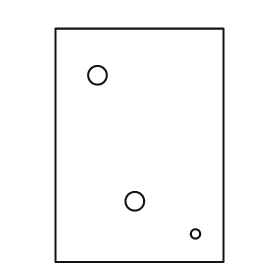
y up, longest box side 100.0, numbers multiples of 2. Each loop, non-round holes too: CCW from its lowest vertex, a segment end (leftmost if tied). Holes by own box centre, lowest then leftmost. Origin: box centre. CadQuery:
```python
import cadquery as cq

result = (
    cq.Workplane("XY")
    .moveTo(-36.0, -50.0)
    .lineTo(36.0, -50.0)
    .lineTo(36.0, 50.0)
    .lineTo(-36.0, 50.0)
    .close()
    .moveTo(24.0, -38.0)
    .circle(2.0)
    .moveTo(-2.0, -24.0)
    .circle(4.0)
    .moveTo(-18.0, 30.0)
    .circle(4.0)
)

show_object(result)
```